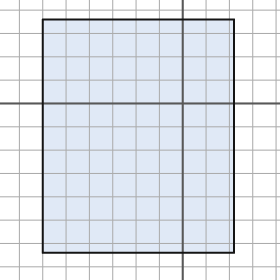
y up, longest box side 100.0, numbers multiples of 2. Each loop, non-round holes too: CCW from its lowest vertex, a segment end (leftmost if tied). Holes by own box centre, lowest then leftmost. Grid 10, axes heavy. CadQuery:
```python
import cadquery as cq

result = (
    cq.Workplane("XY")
    .moveTo(-60.0, -64.0)
    .lineTo(22.0, -64.0)
    .lineTo(22.0, 36.0)
    .lineTo(-60.0, 36.0)
    .close()
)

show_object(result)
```